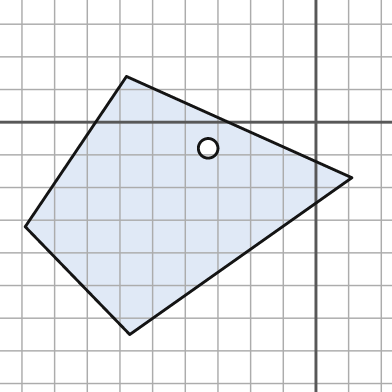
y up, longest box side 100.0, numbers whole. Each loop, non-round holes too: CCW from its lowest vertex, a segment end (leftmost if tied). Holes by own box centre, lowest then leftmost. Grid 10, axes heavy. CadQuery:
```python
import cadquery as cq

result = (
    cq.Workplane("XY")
    .moveTo(-57.0, -65.0)
    .lineTo(11.0, -17.0)
    .lineTo(-58.0, 14.0)
    .lineTo(-89.0, -32.0)
    .close()
    .moveTo(-33.0, -8.0)
    .circle(3.0)
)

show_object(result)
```